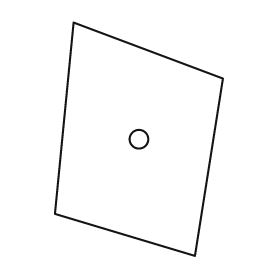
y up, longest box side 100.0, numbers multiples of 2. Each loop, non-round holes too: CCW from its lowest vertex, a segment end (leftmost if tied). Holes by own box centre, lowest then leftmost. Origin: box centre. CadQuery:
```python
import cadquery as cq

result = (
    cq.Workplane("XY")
    .moveTo(24.0, -50.0)
    .lineTo(36.0, 26.0)
    .lineTo(-28.0, 50.0)
    .lineTo(-36.0, -32.0)
    .close()
    .moveTo(0.0, 0.0)
    .circle(4.0)
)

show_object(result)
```